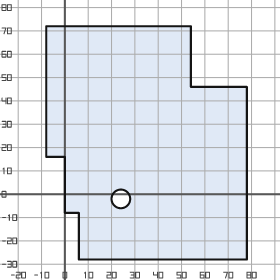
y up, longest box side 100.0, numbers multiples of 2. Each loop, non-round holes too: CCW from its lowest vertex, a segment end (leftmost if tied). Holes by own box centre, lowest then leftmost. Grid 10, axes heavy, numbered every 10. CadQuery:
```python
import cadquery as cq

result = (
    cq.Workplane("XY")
    .moveTo(6.0, -28.0)
    .lineTo(78.0, -28.0)
    .lineTo(78.0, 46.0)
    .lineTo(54.0, 46.0)
    .lineTo(54.0, 72.0)
    .lineTo(-8.0, 72.0)
    .lineTo(-8.0, 16.0)
    .lineTo(0.0, 16.0)
    .lineTo(0.0, -8.0)
    .lineTo(6.0, -8.0)
    .close()
    .moveTo(24.0, -2.0)
    .circle(4.0)
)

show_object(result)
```